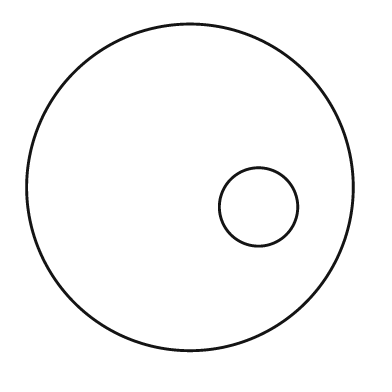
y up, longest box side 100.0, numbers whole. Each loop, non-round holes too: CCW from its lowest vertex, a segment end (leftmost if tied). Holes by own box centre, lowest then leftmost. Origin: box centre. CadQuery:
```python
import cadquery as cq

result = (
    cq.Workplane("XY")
    .moveTo(0.0, 0.0)
    .circle(50.0)
    .moveTo(21.0, -6.0)
    .circle(12.0)
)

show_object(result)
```